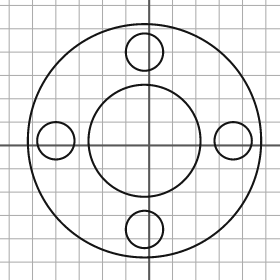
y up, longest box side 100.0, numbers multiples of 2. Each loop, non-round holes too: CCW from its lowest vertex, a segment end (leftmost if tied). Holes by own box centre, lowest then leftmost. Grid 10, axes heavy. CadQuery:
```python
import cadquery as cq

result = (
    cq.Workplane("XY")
    .moveTo(-2.0, 2.0)
    .circle(50.0)
    .moveTo(-2.0, -36.0)
    .circle(8.0)
    .moveTo(-40.0, 2.0)
    .circle(8.0)
    .moveTo(-2.0, 2.0)
    .circle(24.0)
    .moveTo(36.0, 2.0)
    .circle(8.0)
    .moveTo(-2.0, 40.0)
    .circle(8.0)
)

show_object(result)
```